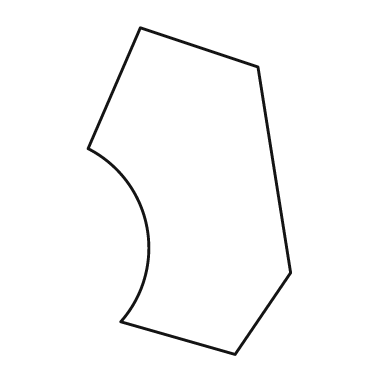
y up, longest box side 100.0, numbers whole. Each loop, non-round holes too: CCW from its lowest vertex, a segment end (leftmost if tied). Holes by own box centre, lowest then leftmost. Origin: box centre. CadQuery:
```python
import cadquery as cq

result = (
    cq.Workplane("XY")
    .moveTo(14.0, -50.0)
    .lineTo(31.0, -25.0)
    .lineTo(21.0, 38.0)
    .lineTo(-15.0, 50.0)
    .lineTo(-31.0, 13.0)
    .threePointArc((-13.0, -11.0), (-21.0, -40.0))
    .close()
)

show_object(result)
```